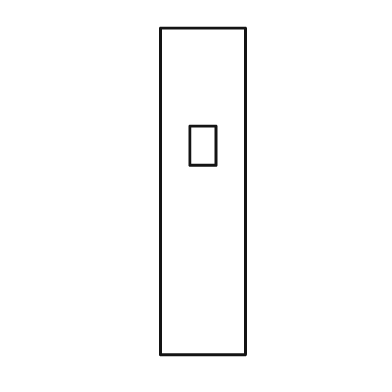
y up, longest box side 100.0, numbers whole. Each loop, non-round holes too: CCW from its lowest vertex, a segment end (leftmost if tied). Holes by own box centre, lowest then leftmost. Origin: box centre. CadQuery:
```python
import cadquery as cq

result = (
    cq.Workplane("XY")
    .moveTo(-13.0, -50.0)
    .lineTo(13.0, -50.0)
    .lineTo(13.0, 50.0)
    .lineTo(-13.0, 50.0)
    .close()
    .moveTo(-4.0, 8.0)
    .lineTo(4.0, 8.0)
    .lineTo(4.0, 20.0)
    .lineTo(-4.0, 20.0)
    .close()
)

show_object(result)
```